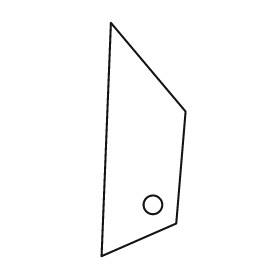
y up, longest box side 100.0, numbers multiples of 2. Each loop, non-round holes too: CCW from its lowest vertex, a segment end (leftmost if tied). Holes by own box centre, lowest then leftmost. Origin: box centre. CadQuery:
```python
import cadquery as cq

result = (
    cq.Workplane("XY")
    .moveTo(-18.0, -50.0)
    .lineTo(14.0, -36.0)
    .lineTo(18.0, 12.0)
    .lineTo(-14.0, 50.0)
    .close()
    .moveTo(4.0, -28.0)
    .circle(4.0)
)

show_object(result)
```